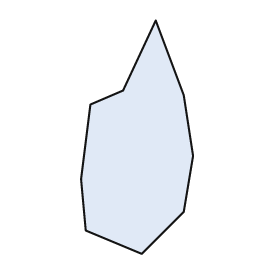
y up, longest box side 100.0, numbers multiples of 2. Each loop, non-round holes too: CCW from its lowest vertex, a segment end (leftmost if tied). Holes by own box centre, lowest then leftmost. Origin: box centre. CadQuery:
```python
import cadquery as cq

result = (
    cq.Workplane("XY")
    .moveTo(2.0, -50.0)
    .lineTo(20.0, -32.0)
    .lineTo(24.0, -8.0)
    .lineTo(20.0, 18.0)
    .lineTo(8.0, 50.0)
    .lineTo(-6.0, 20.0)
    .lineTo(-20.0, 14.0)
    .lineTo(-24.0, -18.0)
    .lineTo(-22.0, -40.0)
    .close()
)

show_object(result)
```